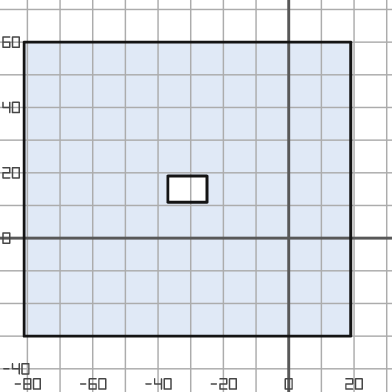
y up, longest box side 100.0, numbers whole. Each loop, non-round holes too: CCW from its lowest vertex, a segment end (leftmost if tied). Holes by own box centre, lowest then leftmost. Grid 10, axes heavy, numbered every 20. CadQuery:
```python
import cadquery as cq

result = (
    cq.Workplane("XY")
    .moveTo(-81.0, -30.0)
    .lineTo(19.0, -30.0)
    .lineTo(19.0, 60.0)
    .lineTo(-81.0, 60.0)
    .close()
    .moveTo(-37.0, 11.0)
    .lineTo(-25.0, 11.0)
    .lineTo(-25.0, 19.0)
    .lineTo(-37.0, 19.0)
    .close()
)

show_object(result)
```